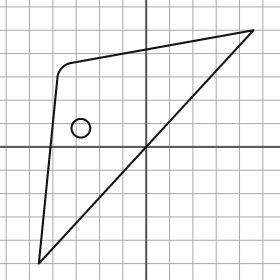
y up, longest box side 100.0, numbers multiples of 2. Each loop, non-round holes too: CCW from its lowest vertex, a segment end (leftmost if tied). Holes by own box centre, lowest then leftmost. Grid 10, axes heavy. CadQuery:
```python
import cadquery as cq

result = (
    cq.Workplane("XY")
    .moveTo(-46.0, -50.0)
    .lineTo(46.0, 50.0)
    .lineTo(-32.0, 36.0)
    .threePointArc((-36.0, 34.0), (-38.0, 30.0))
    .close()
    .moveTo(-28.0, 8.0)
    .circle(4.0)
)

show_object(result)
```